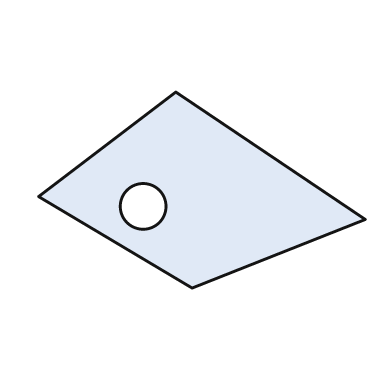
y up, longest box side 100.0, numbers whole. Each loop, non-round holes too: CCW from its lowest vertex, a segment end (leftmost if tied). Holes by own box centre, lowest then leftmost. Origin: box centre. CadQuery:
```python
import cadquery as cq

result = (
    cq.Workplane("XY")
    .moveTo(-3.0, -30.0)
    .lineTo(50.0, -9.0)
    .lineTo(-8.0, 30.0)
    .lineTo(-50.0, -2.0)
    .close()
    .moveTo(-18.0, -5.0)
    .circle(7.0)
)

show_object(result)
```